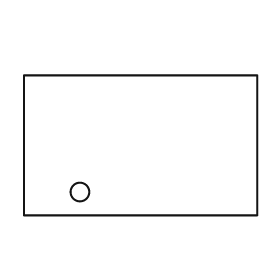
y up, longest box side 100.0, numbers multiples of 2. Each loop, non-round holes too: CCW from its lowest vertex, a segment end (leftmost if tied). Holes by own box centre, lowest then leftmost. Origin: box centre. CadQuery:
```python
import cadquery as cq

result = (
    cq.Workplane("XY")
    .moveTo(-50.0, -30.0)
    .lineTo(50.0, -30.0)
    .lineTo(50.0, 30.0)
    .lineTo(-50.0, 30.0)
    .close()
    .moveTo(-26.0, -20.0)
    .circle(4.0)
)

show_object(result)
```